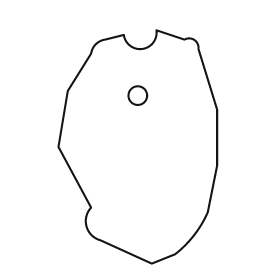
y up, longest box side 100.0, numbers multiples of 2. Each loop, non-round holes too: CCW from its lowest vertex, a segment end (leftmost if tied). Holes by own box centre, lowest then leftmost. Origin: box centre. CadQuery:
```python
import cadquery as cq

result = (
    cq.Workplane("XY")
    .moveTo(6.0, -50.0)
    .lineTo(16.0, -46.0)
    .threePointArc((24.0, -38.0), (30.0, -28.0))
    .lineTo(34.0, -8.0)
    .lineTo(34.0, 16.0)
    .lineTo(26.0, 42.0)
    .threePointArc((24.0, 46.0), (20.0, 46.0))
    .lineTo(8.0, 50.0)
    .threePointArc((2.0, 42.0), (-6.0, 48.0))
    .lineTo(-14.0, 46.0)
    .threePointArc((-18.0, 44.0), (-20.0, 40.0))
    .lineTo(-30.0, 24.0)
    .lineTo(-34.0, 0.0)
    .lineTo(-20.0, -26.0)
    .threePointArc((-22.0, -34.0), (-16.0, -40.0))
    .close()
    .moveTo(0.0, 22.0)
    .circle(4.0)
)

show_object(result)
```